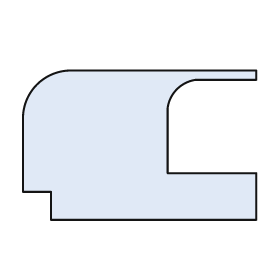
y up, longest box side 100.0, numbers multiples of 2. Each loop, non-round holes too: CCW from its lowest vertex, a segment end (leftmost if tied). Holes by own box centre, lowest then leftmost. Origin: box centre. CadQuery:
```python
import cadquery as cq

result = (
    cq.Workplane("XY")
    .moveTo(-38.0, -32.0)
    .lineTo(50.0, -32.0)
    .lineTo(50.0, -12.0)
    .lineTo(12.0, -12.0)
    .lineTo(12.0, 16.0)
    .threePointArc((16.0, 24.0), (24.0, 28.0))
    .lineTo(50.0, 28.0)
    .lineTo(50.0, 32.0)
    .lineTo(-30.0, 32.0)
    .threePointArc((-44.0, 26.0), (-50.0, 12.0))
    .lineTo(-50.0, -20.0)
    .lineTo(-38.0, -20.0)
    .close()
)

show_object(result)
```